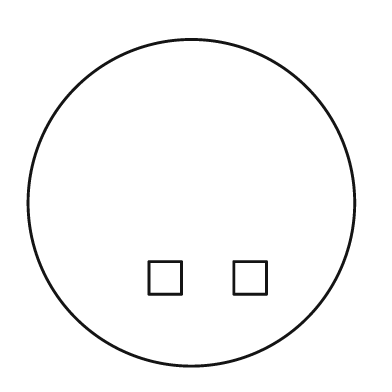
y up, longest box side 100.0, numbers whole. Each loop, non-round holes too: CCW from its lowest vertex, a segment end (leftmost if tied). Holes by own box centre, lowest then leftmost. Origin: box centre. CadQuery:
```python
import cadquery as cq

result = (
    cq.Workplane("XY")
    .moveTo(0.0, 0.0)
    .circle(50.0)
    .moveTo(-13.0, -28.0)
    .lineTo(-3.0, -28.0)
    .lineTo(-3.0, -18.0)
    .lineTo(-13.0, -18.0)
    .close()
    .moveTo(13.0, -28.0)
    .lineTo(23.0, -28.0)
    .lineTo(23.0, -18.0)
    .lineTo(13.0, -18.0)
    .close()
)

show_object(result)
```